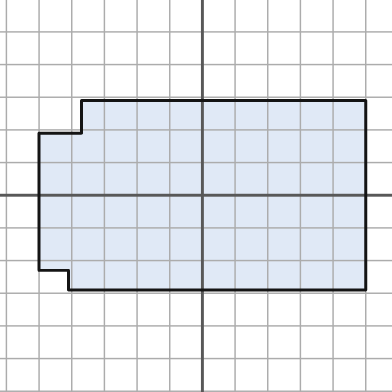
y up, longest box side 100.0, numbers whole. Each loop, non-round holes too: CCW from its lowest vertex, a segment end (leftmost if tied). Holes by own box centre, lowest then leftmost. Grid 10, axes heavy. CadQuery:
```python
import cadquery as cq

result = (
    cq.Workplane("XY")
    .moveTo(-41.0, -29.0)
    .lineTo(50.0, -29.0)
    .lineTo(50.0, 29.0)
    .lineTo(-37.0, 29.0)
    .lineTo(-37.0, 19.0)
    .lineTo(-50.0, 19.0)
    .lineTo(-50.0, -23.0)
    .lineTo(-41.0, -23.0)
    .close()
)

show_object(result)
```